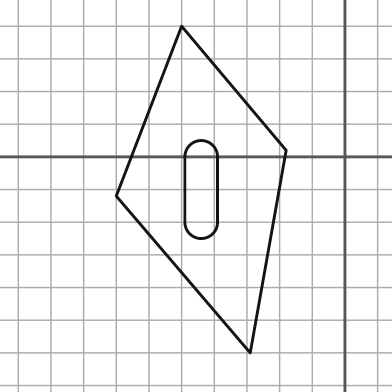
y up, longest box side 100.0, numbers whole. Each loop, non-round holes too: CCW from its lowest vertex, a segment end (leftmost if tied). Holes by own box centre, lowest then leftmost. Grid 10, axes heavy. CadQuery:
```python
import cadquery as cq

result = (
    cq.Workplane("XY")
    .moveTo(-29.0, -60.0)
    .lineTo(-18.0, 2.0)
    .lineTo(-50.0, 40.0)
    .lineTo(-70.0, -12.0)
    .close()
    .moveTo(-49.0, -20.0)
    .threePointArc((-44.0, -25.0), (-39.0, -20.0))
    .lineTo(-39.0, 0.0)
    .threePointArc((-44.0, 5.0), (-49.0, 0.0))
    .close()
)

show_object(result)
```